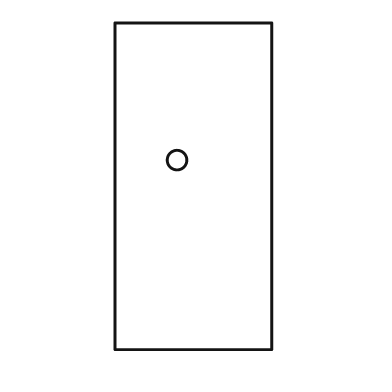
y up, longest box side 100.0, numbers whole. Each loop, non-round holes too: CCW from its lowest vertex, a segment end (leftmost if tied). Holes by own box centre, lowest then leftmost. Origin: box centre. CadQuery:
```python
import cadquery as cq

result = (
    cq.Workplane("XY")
    .moveTo(-24.0, -50.0)
    .lineTo(24.0, -50.0)
    .lineTo(24.0, 50.0)
    .lineTo(-24.0, 50.0)
    .close()
    .moveTo(-5.0, 8.0)
    .circle(3.0)
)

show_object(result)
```